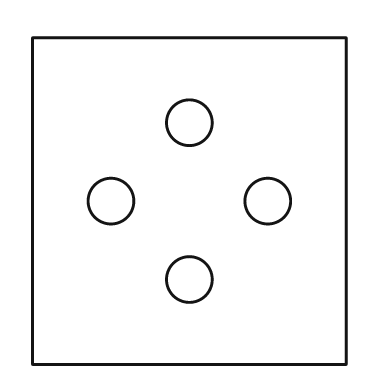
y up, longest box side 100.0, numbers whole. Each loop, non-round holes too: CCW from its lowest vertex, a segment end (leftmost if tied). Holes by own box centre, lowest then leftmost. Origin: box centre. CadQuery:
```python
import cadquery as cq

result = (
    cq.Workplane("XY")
    .moveTo(-48.0, -50.0)
    .lineTo(48.0, -50.0)
    .lineTo(48.0, 50.0)
    .lineTo(-48.0, 50.0)
    .close()
    .moveTo(0.0, -24.0)
    .circle(7.0)
    .moveTo(-24.0, 0.0)
    .circle(7.0)
    .moveTo(24.0, 0.0)
    .circle(7.0)
    .moveTo(0.0, 24.0)
    .circle(7.0)
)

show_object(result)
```